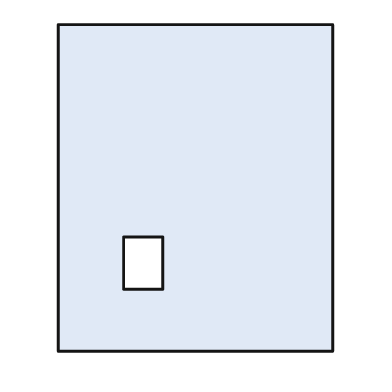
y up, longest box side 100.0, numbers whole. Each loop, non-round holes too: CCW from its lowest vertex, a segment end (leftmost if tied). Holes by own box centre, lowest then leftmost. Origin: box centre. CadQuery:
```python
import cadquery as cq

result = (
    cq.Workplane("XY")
    .moveTo(-42.0, -50.0)
    .lineTo(42.0, -50.0)
    .lineTo(42.0, 50.0)
    .lineTo(-42.0, 50.0)
    .close()
    .moveTo(-22.0, -31.0)
    .lineTo(-10.0, -31.0)
    .lineTo(-10.0, -15.0)
    .lineTo(-22.0, -15.0)
    .close()
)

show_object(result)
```